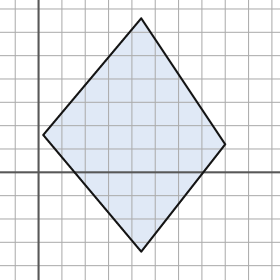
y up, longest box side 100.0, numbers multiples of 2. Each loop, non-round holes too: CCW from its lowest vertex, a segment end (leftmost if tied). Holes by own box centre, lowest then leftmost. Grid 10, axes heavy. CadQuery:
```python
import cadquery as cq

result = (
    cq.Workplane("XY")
    .moveTo(44.0, -34.0)
    .lineTo(80.0, 12.0)
    .lineTo(44.0, 66.0)
    .lineTo(2.0, 16.0)
    .close()
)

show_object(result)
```